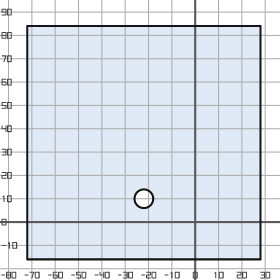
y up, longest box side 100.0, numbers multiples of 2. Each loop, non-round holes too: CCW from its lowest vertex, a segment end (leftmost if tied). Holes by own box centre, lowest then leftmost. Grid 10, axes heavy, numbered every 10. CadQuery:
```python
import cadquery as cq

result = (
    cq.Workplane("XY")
    .moveTo(-72.0, -16.0)
    .lineTo(28.0, -16.0)
    .lineTo(28.0, 84.0)
    .lineTo(-72.0, 84.0)
    .close()
    .moveTo(-22.0, 10.0)
    .circle(4.0)
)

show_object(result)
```